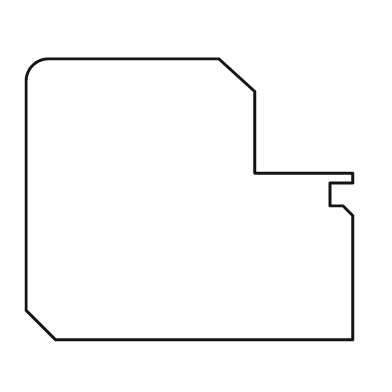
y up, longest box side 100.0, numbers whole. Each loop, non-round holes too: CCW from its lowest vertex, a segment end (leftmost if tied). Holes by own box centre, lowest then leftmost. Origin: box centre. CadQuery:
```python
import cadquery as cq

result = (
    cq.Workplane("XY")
    .moveTo(-41.0, -43.0)
    .lineTo(50.0, -43.0)
    .lineTo(50.0, -5.0)
    .lineTo(47.0, -2.0)
    .lineTo(43.0, -2.0)
    .lineTo(43.0, 5.0)
    .lineTo(50.0, 5.0)
    .lineTo(50.0, 8.0)
    .lineTo(20.0, 8.0)
    .lineTo(20.0, 33.0)
    .lineTo(9.0, 43.0)
    .lineTo(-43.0, 43.0)
    .threePointArc((-48.0, 41.0), (-50.0, 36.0))
    .lineTo(-50.0, -34.0)
    .close()
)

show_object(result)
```